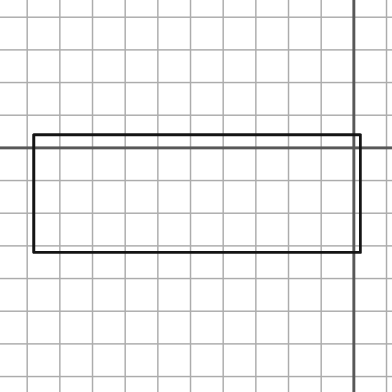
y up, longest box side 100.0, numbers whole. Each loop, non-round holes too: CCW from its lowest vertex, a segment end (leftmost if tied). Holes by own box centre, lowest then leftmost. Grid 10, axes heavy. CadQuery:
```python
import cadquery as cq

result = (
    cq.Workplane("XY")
    .moveTo(-98.0, -32.0)
    .lineTo(2.0, -32.0)
    .lineTo(2.0, 4.0)
    .lineTo(-98.0, 4.0)
    .close()
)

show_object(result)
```